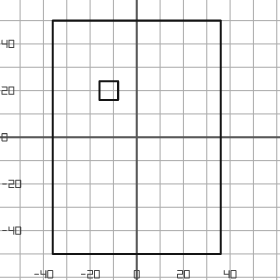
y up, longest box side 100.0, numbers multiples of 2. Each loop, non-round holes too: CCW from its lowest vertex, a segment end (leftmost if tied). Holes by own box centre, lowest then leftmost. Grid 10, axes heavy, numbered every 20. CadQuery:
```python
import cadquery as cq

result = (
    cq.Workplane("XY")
    .moveTo(-36.0, -50.0)
    .lineTo(36.0, -50.0)
    .lineTo(36.0, 50.0)
    .lineTo(-36.0, 50.0)
    .close()
    .moveTo(-16.0, 16.0)
    .lineTo(-8.0, 16.0)
    .lineTo(-8.0, 24.0)
    .lineTo(-16.0, 24.0)
    .close()
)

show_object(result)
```